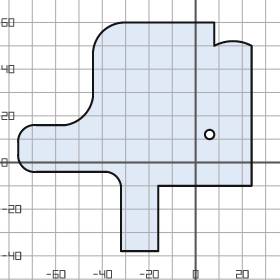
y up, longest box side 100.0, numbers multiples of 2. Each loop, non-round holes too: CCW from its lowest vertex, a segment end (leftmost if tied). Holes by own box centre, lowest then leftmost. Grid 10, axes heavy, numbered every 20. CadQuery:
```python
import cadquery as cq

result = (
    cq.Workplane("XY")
    .moveTo(-32.0, -38.0)
    .lineTo(-16.0, -38.0)
    .lineTo(-16.0, -10.0)
    .lineTo(24.0, -10.0)
    .lineTo(24.0, 50.0)
    .threePointArc((16.0, 52.0), (8.0, 50.0))
    .lineTo(8.0, 60.0)
    .lineTo(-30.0, 60.0)
    .threePointArc((-40.0, 56.0), (-44.0, 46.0))
    .lineTo(-44.0, 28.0)
    .threePointArc((-48.0, 20.0), (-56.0, 16.0))
    .lineTo(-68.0, 16.0)
    .threePointArc((-74.0, 14.0), (-76.0, 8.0))
    .lineTo(-76.0, 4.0)
    .threePointArc((-74.0, -2.0), (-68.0, -4.0))
    .lineTo(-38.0, -4.0)
    .threePointArc((-34.0, -6.0), (-32.0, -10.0))
    .close()
    .moveTo(6.0, 12.0)
    .circle(2.0)
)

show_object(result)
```